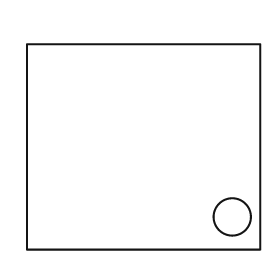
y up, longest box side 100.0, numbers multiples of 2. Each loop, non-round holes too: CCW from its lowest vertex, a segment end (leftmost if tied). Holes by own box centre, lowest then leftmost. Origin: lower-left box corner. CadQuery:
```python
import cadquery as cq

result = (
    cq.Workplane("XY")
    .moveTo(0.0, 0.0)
    .lineTo(100.0, 0.0)
    .lineTo(100.0, 88.0)
    .lineTo(0.0, 88.0)
    .close()
    .moveTo(88.0, 14.0)
    .circle(8.0)
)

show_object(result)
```